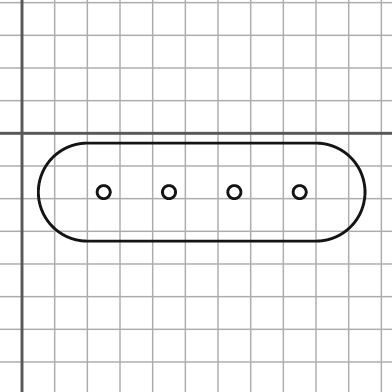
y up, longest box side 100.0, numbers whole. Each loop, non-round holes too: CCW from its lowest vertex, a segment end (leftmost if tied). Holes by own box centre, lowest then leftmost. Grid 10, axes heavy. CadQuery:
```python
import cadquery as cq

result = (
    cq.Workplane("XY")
    .moveTo(20.0, -33.0)
    .lineTo(90.0, -33.0)
    .threePointArc((105.0, -18.0), (90.0, -3.0))
    .lineTo(20.0, -3.0)
    .threePointArc((5.0, -18.0), (20.0, -33.0))
    .close()
    .moveTo(25.0, -18.0)
    .circle(2.0)
    .moveTo(45.0, -18.0)
    .circle(2.0)
    .moveTo(65.0, -18.0)
    .circle(2.0)
    .moveTo(85.0, -18.0)
    .circle(2.0)
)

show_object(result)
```